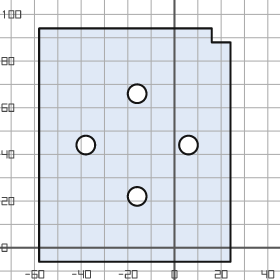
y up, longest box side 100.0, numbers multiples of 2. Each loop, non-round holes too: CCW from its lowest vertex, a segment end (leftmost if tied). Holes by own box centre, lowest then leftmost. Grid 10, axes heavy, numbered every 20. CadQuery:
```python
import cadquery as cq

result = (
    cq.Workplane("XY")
    .moveTo(-58.0, -6.0)
    .lineTo(24.0, -6.0)
    .lineTo(24.0, 88.0)
    .lineTo(16.0, 88.0)
    .lineTo(16.0, 94.0)
    .lineTo(-58.0, 94.0)
    .close()
    .moveTo(-16.0, 22.0)
    .circle(4.0)
    .moveTo(-38.0, 44.0)
    .circle(4.0)
    .moveTo(6.0, 44.0)
    .circle(4.0)
    .moveTo(-16.0, 66.0)
    .circle(4.0)
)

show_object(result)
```